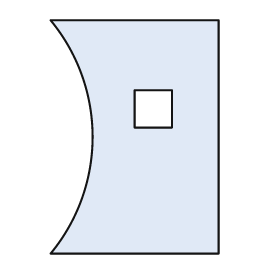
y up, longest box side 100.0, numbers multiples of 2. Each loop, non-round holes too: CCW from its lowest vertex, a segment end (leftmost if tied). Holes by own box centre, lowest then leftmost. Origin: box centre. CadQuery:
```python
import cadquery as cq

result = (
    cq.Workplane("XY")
    .moveTo(-36.0, -50.0)
    .lineTo(36.0, -50.0)
    .lineTo(36.0, 50.0)
    .lineTo(-36.0, 50.0)
    .threePointArc((-18.0, 0.0), (-36.0, -50.0))
    .close()
    .moveTo(0.0, 4.0)
    .lineTo(16.0, 4.0)
    .lineTo(16.0, 20.0)
    .lineTo(0.0, 20.0)
    .close()
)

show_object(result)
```